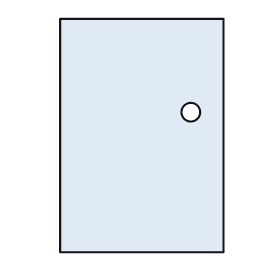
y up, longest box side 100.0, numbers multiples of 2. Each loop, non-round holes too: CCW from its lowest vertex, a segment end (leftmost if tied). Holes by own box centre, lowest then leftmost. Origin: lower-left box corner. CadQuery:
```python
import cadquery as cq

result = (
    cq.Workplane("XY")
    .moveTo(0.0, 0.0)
    .lineTo(70.0, 0.0)
    .lineTo(70.0, 100.0)
    .lineTo(0.0, 100.0)
    .close()
    .moveTo(56.0, 60.0)
    .circle(4.0)
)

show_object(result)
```